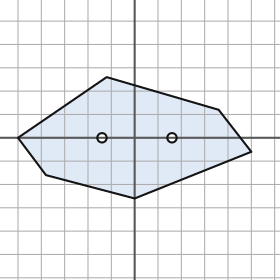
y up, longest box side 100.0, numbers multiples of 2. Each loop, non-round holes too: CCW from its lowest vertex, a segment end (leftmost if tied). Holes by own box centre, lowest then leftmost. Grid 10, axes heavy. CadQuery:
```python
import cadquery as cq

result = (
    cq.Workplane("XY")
    .moveTo(0.0, -26.0)
    .lineTo(50.0, -6.0)
    .lineTo(36.0, 12.0)
    .lineTo(-12.0, 26.0)
    .lineTo(-50.0, 0.0)
    .lineTo(-38.0, -16.0)
    .close()
    .moveTo(-14.0, 0.0)
    .circle(2.0)
    .moveTo(16.0, 0.0)
    .circle(2.0)
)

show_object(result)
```